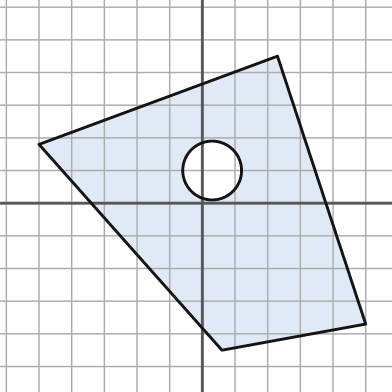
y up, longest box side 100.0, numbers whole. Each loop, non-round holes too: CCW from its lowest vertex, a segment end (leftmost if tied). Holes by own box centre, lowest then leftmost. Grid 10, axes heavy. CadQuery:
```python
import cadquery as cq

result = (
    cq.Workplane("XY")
    .moveTo(6.0, -45.0)
    .lineTo(50.0, -37.0)
    .lineTo(23.0, 45.0)
    .lineTo(-50.0, 18.0)
    .close()
    .moveTo(3.0, 10.0)
    .circle(9.0)
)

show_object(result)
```